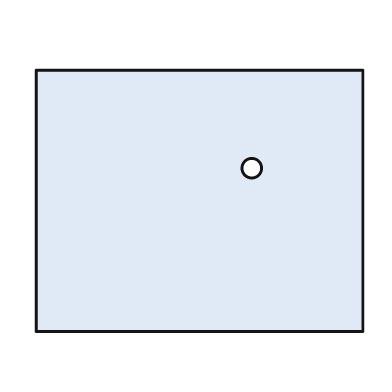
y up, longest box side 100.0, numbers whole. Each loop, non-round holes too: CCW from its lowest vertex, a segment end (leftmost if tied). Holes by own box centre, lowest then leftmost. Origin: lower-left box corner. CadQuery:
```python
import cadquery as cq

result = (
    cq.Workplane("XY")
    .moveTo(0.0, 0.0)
    .lineTo(100.0, 0.0)
    .lineTo(100.0, 80.0)
    .lineTo(0.0, 80.0)
    .close()
    .moveTo(66.0, 50.0)
    .circle(3.0)
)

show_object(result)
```